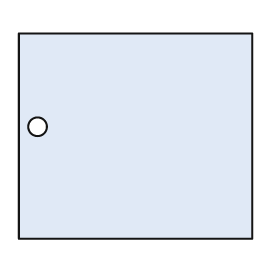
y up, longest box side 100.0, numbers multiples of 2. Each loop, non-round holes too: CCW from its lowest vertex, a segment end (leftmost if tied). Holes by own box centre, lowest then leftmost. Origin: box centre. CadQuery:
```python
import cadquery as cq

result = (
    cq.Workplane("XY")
    .moveTo(-50.0, -44.0)
    .lineTo(50.0, -44.0)
    .lineTo(50.0, 44.0)
    .lineTo(-50.0, 44.0)
    .close()
    .moveTo(-42.0, 4.0)
    .circle(4.0)
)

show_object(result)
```